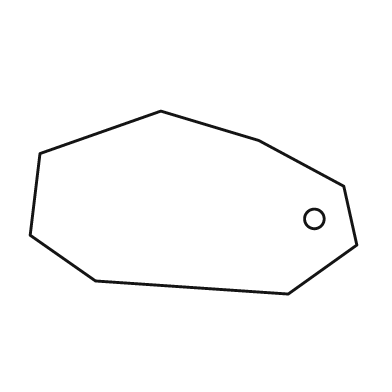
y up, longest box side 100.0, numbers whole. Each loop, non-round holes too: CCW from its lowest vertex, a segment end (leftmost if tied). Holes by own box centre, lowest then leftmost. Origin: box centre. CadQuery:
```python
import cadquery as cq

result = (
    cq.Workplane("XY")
    .moveTo(29.0, -28.0)
    .lineTo(50.0, -13.0)
    .lineTo(46.0, 5.0)
    .lineTo(20.0, 19.0)
    .lineTo(-10.0, 28.0)
    .lineTo(-47.0, 15.0)
    .lineTo(-50.0, -10.0)
    .lineTo(-30.0, -24.0)
    .close()
    .moveTo(37.0, -5.0)
    .circle(3.0)
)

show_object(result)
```